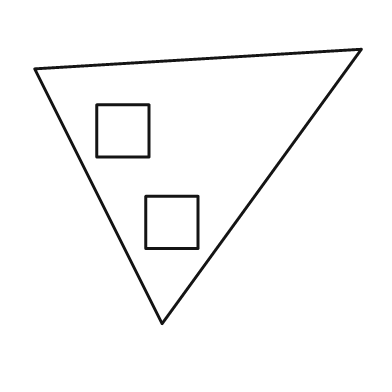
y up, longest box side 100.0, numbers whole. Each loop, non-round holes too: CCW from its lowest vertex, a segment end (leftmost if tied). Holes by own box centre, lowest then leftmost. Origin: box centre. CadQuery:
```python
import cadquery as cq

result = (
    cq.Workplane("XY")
    .moveTo(-11.0, -42.0)
    .lineTo(50.0, 42.0)
    .lineTo(-50.0, 36.0)
    .close()
    .moveTo(-16.0, -19.0)
    .lineTo(0.0, -19.0)
    .lineTo(0.0, -3.0)
    .lineTo(-16.0, -3.0)
    .close()
    .moveTo(-31.0, 9.0)
    .lineTo(-15.0, 9.0)
    .lineTo(-15.0, 25.0)
    .lineTo(-31.0, 25.0)
    .close()
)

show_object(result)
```